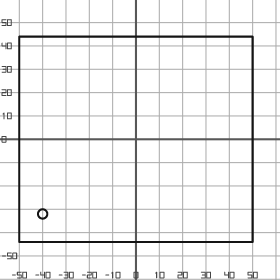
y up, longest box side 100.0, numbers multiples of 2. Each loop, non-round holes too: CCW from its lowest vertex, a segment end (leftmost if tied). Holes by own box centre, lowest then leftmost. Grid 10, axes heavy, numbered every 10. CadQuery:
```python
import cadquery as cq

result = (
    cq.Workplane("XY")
    .moveTo(-50.0, -44.0)
    .lineTo(50.0, -44.0)
    .lineTo(50.0, 44.0)
    .lineTo(-50.0, 44.0)
    .close()
    .moveTo(-40.0, -32.0)
    .circle(2.0)
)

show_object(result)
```